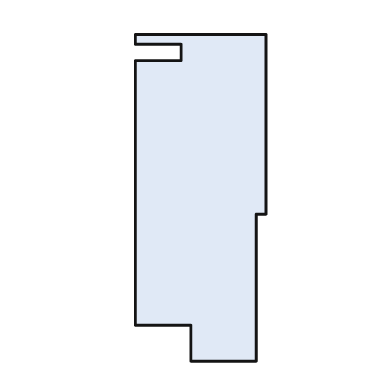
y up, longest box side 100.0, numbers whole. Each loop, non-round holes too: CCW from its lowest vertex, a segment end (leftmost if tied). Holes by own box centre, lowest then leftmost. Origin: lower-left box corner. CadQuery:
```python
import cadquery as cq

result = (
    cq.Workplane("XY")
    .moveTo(17.0, 0.0)
    .lineTo(37.0, 0.0)
    .lineTo(37.0, 45.0)
    .lineTo(40.0, 45.0)
    .lineTo(40.0, 100.0)
    .lineTo(0.0, 100.0)
    .lineTo(0.0, 97.0)
    .lineTo(14.0, 97.0)
    .lineTo(14.0, 92.0)
    .lineTo(0.0, 92.0)
    .lineTo(0.0, 11.0)
    .lineTo(17.0, 11.0)
    .close()
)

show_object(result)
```